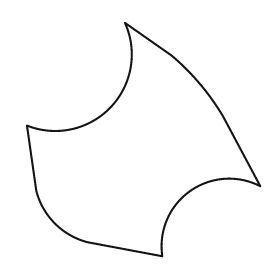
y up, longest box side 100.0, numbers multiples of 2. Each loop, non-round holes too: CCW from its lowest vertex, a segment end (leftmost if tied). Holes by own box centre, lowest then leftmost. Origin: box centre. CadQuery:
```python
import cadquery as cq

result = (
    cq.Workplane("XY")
    .moveTo(8.0, -50.0)
    .threePointArc((20.0, -22.0), (50.0, -20.0))
    .lineTo(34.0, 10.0)
    .threePointArc((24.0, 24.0), (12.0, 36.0))
    .lineTo(-8.0, 50.0)
    .threePointArc((-14.0, 14.0), (-50.0, 6.0))
    .lineTo(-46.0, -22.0)
    .threePointArc((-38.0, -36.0), (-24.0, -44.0))
    .close()
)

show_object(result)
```